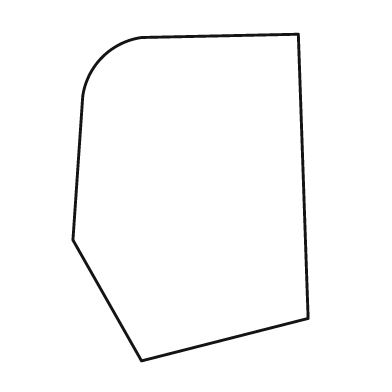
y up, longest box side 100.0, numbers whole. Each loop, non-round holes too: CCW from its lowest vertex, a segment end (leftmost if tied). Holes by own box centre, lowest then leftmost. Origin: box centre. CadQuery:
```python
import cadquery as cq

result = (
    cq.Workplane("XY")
    .moveTo(-15.0, -50.0)
    .lineTo(36.0, -37.0)
    .lineTo(33.0, 50.0)
    .lineTo(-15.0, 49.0)
    .threePointArc((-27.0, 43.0), (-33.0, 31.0))
    .lineTo(-36.0, -13.0)
    .close()
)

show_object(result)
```